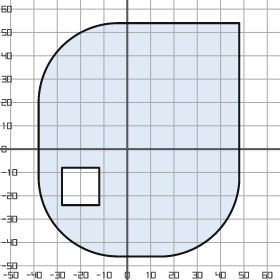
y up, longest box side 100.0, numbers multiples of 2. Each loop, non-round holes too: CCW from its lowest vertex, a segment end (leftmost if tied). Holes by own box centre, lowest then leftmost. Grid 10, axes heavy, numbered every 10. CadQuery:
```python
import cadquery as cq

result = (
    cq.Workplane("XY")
    .moveTo(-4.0, -46.0)
    .lineTo(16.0, -46.0)
    .threePointArc((38.0, -36.0), (48.0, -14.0))
    .lineTo(48.0, 54.0)
    .lineTo(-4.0, 54.0)
    .threePointArc((-28.0, 44.0), (-38.0, 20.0))
    .lineTo(-38.0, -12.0)
    .threePointArc((-28.0, -36.0), (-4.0, -46.0))
    .close()
    .moveTo(-28.0, -24.0)
    .lineTo(-12.0, -24.0)
    .lineTo(-12.0, -8.0)
    .lineTo(-28.0, -8.0)
    .close()
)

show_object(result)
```